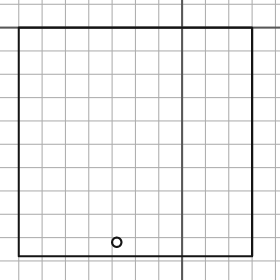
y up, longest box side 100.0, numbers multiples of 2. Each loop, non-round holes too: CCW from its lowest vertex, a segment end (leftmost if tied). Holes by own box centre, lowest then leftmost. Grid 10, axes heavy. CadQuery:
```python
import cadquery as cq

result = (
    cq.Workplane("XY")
    .moveTo(-70.0, -98.0)
    .lineTo(30.0, -98.0)
    .lineTo(30.0, 0.0)
    .lineTo(-70.0, 0.0)
    .close()
    .moveTo(-28.0, -92.0)
    .circle(2.0)
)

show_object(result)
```